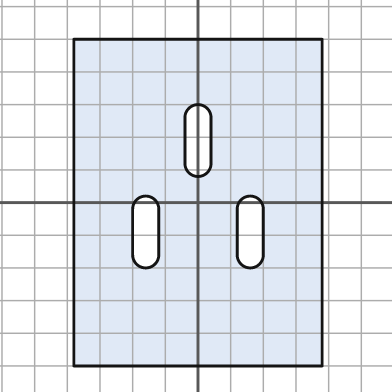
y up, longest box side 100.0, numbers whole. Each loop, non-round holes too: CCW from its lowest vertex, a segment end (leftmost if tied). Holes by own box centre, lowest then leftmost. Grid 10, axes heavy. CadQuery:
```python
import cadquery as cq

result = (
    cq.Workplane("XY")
    .moveTo(-38.0, -50.0)
    .lineTo(38.0, -50.0)
    .lineTo(38.0, 50.0)
    .lineTo(-38.0, 50.0)
    .close()
    .moveTo(-20.0, -16.0)
    .threePointArc((-16.0, -20.0), (-12.0, -16.0))
    .lineTo(-12.0, -2.0)
    .threePointArc((-16.0, 2.0), (-20.0, -2.0))
    .close()
    .moveTo(12.0, -16.0)
    .threePointArc((16.0, -20.0), (20.0, -16.0))
    .lineTo(20.0, -2.0)
    .threePointArc((16.0, 2.0), (12.0, -2.0))
    .close()
    .moveTo(-4.0, 12.0)
    .threePointArc((0.0, 8.0), (4.0, 12.0))
    .lineTo(4.0, 26.0)
    .threePointArc((0.0, 30.0), (-4.0, 26.0))
    .close()
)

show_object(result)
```